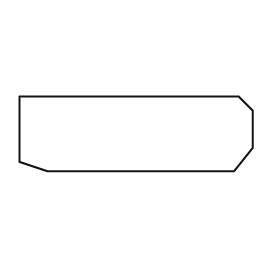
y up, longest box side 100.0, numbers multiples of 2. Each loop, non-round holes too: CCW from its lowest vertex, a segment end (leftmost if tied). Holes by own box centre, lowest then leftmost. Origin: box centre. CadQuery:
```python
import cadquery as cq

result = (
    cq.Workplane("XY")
    .moveTo(-38.0, -16.0)
    .lineTo(42.0, -16.0)
    .lineTo(50.0, -6.0)
    .lineTo(50.0, 10.0)
    .lineTo(44.0, 16.0)
    .lineTo(-50.0, 16.0)
    .lineTo(-50.0, -12.0)
    .close()
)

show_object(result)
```